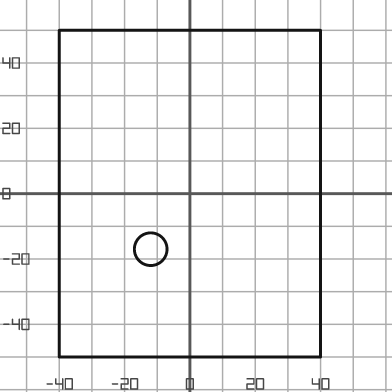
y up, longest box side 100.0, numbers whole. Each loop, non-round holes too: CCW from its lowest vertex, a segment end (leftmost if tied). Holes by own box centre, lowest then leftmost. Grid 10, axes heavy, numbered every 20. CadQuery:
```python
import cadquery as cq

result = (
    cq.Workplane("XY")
    .moveTo(-40.0, -50.0)
    .lineTo(40.0, -50.0)
    .lineTo(40.0, 50.0)
    .lineTo(-40.0, 50.0)
    .close()
    .moveTo(-12.0, -17.0)
    .circle(5.0)
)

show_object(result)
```